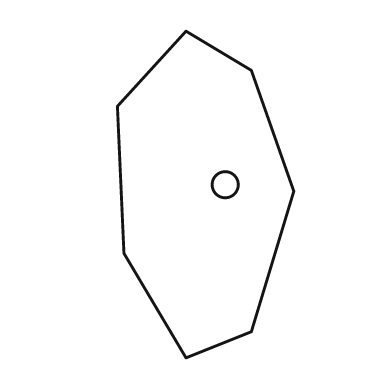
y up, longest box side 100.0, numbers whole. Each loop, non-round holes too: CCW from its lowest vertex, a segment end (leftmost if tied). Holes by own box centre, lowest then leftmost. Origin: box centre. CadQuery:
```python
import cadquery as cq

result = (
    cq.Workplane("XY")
    .moveTo(-6.0, -50.0)
    .lineTo(14.0, -42.0)
    .lineTo(27.0, 1.0)
    .lineTo(14.0, 38.0)
    .lineTo(-6.0, 50.0)
    .lineTo(-27.0, 27.0)
    .lineTo(-25.0, -18.0)
    .close()
    .moveTo(6.0, 3.0)
    .circle(4.0)
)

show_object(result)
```